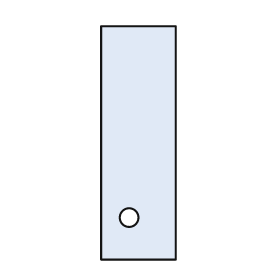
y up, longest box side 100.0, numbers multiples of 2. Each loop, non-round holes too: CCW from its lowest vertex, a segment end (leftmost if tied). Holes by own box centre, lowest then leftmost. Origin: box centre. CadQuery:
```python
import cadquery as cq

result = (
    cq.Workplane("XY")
    .moveTo(-16.0, -50.0)
    .lineTo(16.0, -50.0)
    .lineTo(16.0, 50.0)
    .lineTo(-16.0, 50.0)
    .close()
    .moveTo(-4.0, -32.0)
    .circle(4.0)
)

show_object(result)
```